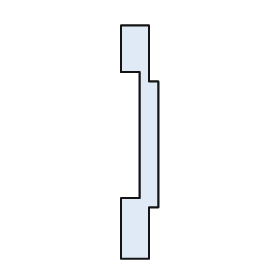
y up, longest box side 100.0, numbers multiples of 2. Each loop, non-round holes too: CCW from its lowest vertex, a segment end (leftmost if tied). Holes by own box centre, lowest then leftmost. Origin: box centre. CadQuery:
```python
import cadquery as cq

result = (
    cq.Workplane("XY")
    .moveTo(-8.0, -50.0)
    .lineTo(4.0, -50.0)
    .lineTo(4.0, -28.0)
    .lineTo(8.0, -28.0)
    .lineTo(8.0, 26.0)
    .lineTo(4.0, 26.0)
    .lineTo(4.0, 50.0)
    .lineTo(-8.0, 50.0)
    .lineTo(-8.0, 30.0)
    .lineTo(0.0, 30.0)
    .lineTo(0.0, -24.0)
    .lineTo(-8.0, -24.0)
    .close()
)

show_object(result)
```